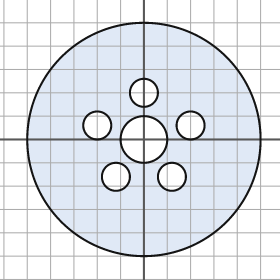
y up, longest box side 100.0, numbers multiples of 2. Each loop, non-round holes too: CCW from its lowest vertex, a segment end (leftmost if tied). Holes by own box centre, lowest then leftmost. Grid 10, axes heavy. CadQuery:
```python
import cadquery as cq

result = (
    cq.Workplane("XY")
    .moveTo(0.0, 0.0)
    .circle(50.0)
    .moveTo(-12.0, -16.0)
    .circle(6.0)
    .moveTo(12.0, -16.0)
    .circle(6.0)
    .moveTo(0.0, 0.0)
    .circle(10.0)
    .moveTo(-20.0, 6.0)
    .circle(6.0)
    .moveTo(20.0, 6.0)
    .circle(6.0)
    .moveTo(0.0, 20.0)
    .circle(6.0)
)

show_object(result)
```